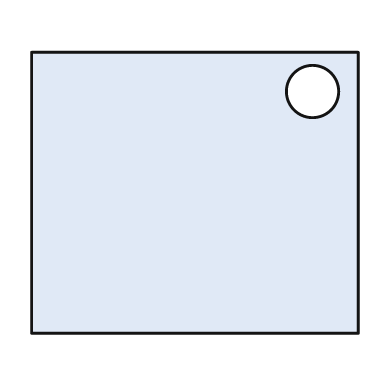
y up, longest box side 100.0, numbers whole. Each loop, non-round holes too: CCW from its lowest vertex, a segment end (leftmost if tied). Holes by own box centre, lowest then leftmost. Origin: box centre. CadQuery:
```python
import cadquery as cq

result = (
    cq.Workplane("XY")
    .moveTo(-50.0, -43.0)
    .lineTo(50.0, -43.0)
    .lineTo(50.0, 43.0)
    .lineTo(-50.0, 43.0)
    .close()
    .moveTo(36.0, 31.0)
    .circle(8.0)
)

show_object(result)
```